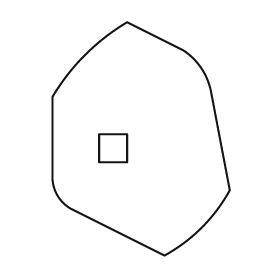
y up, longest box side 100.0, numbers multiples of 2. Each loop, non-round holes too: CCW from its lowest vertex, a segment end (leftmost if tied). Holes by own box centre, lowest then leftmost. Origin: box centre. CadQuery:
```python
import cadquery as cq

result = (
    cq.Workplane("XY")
    .moveTo(10.0, -50.0)
    .threePointArc((26.0, -38.0), (38.0, -22.0))
    .lineTo(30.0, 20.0)
    .threePointArc((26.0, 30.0), (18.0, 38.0))
    .lineTo(-6.0, 50.0)
    .threePointArc((-24.0, 36.0), (-38.0, 18.0))
    .lineTo(-38.0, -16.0)
    .threePointArc((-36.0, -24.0), (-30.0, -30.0))
    .close()
    .moveTo(-18.0, -10.0)
    .lineTo(-6.0, -10.0)
    .lineTo(-6.0, 2.0)
    .lineTo(-18.0, 2.0)
    .close()
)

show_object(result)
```